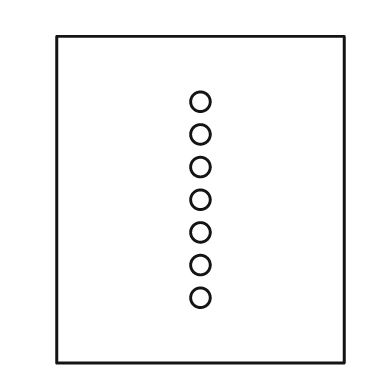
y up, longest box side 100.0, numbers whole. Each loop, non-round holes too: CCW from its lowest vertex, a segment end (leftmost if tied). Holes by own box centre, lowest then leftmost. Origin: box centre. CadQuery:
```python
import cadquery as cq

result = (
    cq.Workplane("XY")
    .moveTo(-44.0, -50.0)
    .lineTo(44.0, -50.0)
    .lineTo(44.0, 50.0)
    .lineTo(-44.0, 50.0)
    .close()
    .moveTo(0.0, -30.0)
    .circle(3.0)
    .moveTo(0.0, -20.0)
    .circle(3.0)
    .moveTo(0.0, -10.0)
    .circle(3.0)
    .moveTo(0.0, 0.0)
    .circle(3.0)
    .moveTo(0.0, 10.0)
    .circle(3.0)
    .moveTo(0.0, 20.0)
    .circle(3.0)
    .moveTo(0.0, 30.0)
    .circle(3.0)
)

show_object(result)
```